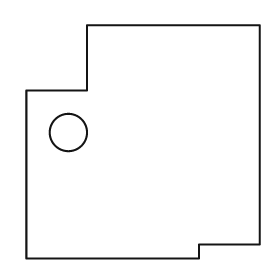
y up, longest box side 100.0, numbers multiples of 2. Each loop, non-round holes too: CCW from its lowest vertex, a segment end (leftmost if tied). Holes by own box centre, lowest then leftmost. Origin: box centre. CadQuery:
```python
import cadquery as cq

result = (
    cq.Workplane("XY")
    .moveTo(-50.0, -50.0)
    .lineTo(24.0, -50.0)
    .lineTo(24.0, -44.0)
    .lineTo(50.0, -44.0)
    .lineTo(50.0, 50.0)
    .lineTo(-24.0, 50.0)
    .lineTo(-24.0, 22.0)
    .lineTo(-50.0, 22.0)
    .close()
    .moveTo(-32.0, 4.0)
    .circle(8.0)
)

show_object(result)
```